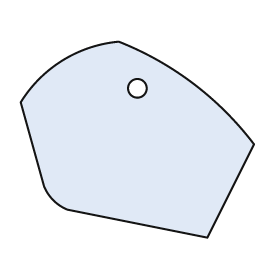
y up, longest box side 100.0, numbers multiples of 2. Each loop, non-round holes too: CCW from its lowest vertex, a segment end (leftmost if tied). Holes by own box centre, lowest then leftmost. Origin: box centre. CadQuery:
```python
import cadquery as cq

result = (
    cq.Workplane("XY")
    .moveTo(30.0, -42.0)
    .lineTo(50.0, -2.0)
    .threePointArc((24.0, 24.0), (-8.0, 42.0))
    .threePointArc((-32.0, 34.0), (-50.0, 16.0))
    .lineTo(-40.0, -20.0)
    .threePointArc((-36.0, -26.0), (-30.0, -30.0))
    .close()
    .moveTo(0.0, 22.0)
    .circle(4.0)
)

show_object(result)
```